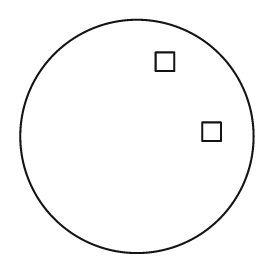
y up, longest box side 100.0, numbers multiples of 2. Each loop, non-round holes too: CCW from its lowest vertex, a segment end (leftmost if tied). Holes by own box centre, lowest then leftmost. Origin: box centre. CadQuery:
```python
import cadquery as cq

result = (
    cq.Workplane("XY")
    .moveTo(0.0, 0.0)
    .circle(50.0)
    .moveTo(28.0, -2.0)
    .lineTo(36.0, -2.0)
    .lineTo(36.0, 6.0)
    .lineTo(28.0, 6.0)
    .close()
    .moveTo(8.0, 28.0)
    .lineTo(16.0, 28.0)
    .lineTo(16.0, 36.0)
    .lineTo(8.0, 36.0)
    .close()
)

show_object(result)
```